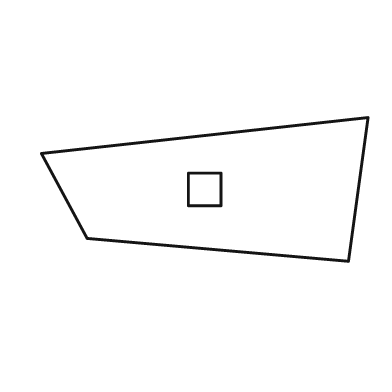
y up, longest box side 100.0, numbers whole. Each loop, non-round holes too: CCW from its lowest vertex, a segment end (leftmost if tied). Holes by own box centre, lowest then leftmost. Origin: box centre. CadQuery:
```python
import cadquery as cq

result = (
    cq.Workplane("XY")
    .moveTo(44.0, -22.0)
    .lineTo(50.0, 22.0)
    .lineTo(-50.0, 11.0)
    .lineTo(-36.0, -15.0)
    .close()
    .moveTo(-5.0, -5.0)
    .lineTo(5.0, -5.0)
    .lineTo(5.0, 5.0)
    .lineTo(-5.0, 5.0)
    .close()
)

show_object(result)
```